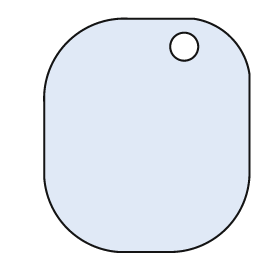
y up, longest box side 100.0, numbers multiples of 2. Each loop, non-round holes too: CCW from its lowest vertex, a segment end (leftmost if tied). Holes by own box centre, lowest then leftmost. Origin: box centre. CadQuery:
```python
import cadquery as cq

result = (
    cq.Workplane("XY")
    .moveTo(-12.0, -50.0)
    .lineTo(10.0, -50.0)
    .threePointArc((34.0, -40.0), (44.0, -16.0))
    .lineTo(44.0, 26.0)
    .threePointArc((36.0, 42.0), (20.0, 50.0))
    .lineTo(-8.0, 50.0)
    .threePointArc((-34.0, 40.0), (-44.0, 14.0))
    .lineTo(-44.0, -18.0)
    .threePointArc((-34.0, -40.0), (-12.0, -50.0))
    .close()
    .moveTo(16.0, 38.0)
    .circle(6.0)
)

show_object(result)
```